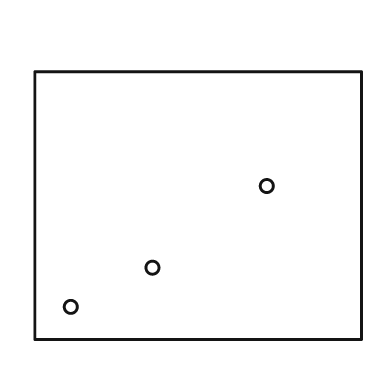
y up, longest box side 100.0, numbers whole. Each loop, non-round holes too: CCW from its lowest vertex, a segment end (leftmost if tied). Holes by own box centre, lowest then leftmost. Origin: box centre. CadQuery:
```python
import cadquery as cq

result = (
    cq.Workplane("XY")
    .moveTo(-50.0, -41.0)
    .lineTo(50.0, -41.0)
    .lineTo(50.0, 41.0)
    .lineTo(-50.0, 41.0)
    .close()
    .moveTo(-39.0, -31.0)
    .circle(2.0)
    .moveTo(-14.0, -19.0)
    .circle(2.0)
    .moveTo(21.0, 6.0)
    .circle(2.0)
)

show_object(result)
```